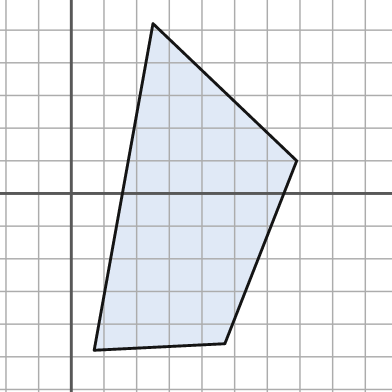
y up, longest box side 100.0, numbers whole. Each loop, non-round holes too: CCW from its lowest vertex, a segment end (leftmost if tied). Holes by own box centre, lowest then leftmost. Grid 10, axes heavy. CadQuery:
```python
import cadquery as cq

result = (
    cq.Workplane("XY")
    .moveTo(7.0, -48.0)
    .lineTo(47.0, -46.0)
    .lineTo(69.0, 10.0)
    .lineTo(25.0, 52.0)
    .close()
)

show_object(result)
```